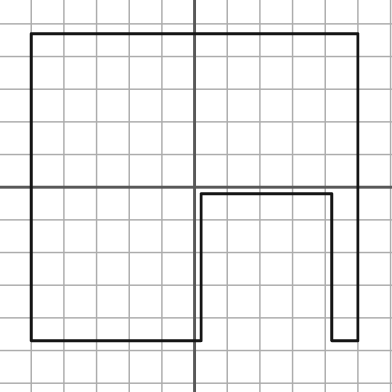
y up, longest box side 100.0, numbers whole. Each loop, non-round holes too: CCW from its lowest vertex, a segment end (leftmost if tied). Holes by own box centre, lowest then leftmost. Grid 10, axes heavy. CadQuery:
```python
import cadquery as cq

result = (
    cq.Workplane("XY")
    .moveTo(-50.0, -47.0)
    .lineTo(2.0, -47.0)
    .lineTo(2.0, -2.0)
    .lineTo(42.0, -2.0)
    .lineTo(42.0, -47.0)
    .lineTo(50.0, -47.0)
    .lineTo(50.0, 47.0)
    .lineTo(-50.0, 47.0)
    .close()
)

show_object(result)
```